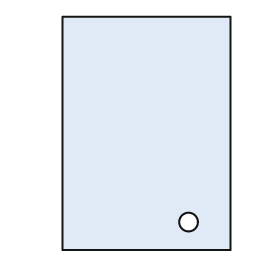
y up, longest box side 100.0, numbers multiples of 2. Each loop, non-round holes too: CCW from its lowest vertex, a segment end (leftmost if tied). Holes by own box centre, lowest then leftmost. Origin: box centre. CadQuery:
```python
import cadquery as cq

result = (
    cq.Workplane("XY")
    .moveTo(-36.0, -50.0)
    .lineTo(36.0, -50.0)
    .lineTo(36.0, 50.0)
    .lineTo(-36.0, 50.0)
    .close()
    .moveTo(18.0, -38.0)
    .circle(4.0)
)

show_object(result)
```